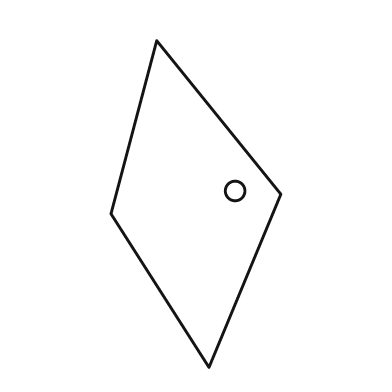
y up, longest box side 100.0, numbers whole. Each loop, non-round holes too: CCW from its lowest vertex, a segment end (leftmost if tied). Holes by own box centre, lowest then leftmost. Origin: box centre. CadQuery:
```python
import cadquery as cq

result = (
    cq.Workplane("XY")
    .moveTo(4.0, -50.0)
    .lineTo(26.0, 3.0)
    .lineTo(-12.0, 50.0)
    .lineTo(-26.0, -3.0)
    .close()
    .moveTo(12.0, 4.0)
    .circle(3.0)
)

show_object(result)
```